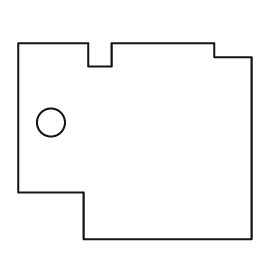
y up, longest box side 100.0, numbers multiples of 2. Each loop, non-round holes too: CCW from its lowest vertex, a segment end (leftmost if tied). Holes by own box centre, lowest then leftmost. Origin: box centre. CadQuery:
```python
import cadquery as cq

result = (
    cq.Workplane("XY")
    .moveTo(-22.0, -42.0)
    .lineTo(50.0, -42.0)
    .lineTo(50.0, 36.0)
    .lineTo(34.0, 36.0)
    .lineTo(34.0, 42.0)
    .lineTo(-10.0, 42.0)
    .lineTo(-10.0, 32.0)
    .lineTo(-20.0, 32.0)
    .lineTo(-20.0, 42.0)
    .lineTo(-50.0, 42.0)
    .lineTo(-50.0, -22.0)
    .lineTo(-22.0, -22.0)
    .close()
    .moveTo(-36.0, 8.0)
    .circle(6.0)
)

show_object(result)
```